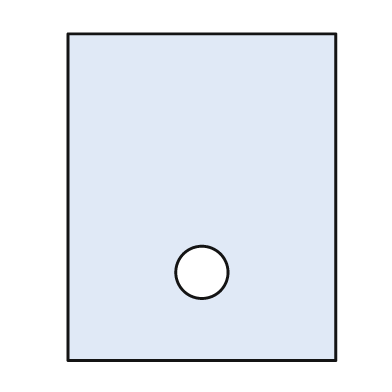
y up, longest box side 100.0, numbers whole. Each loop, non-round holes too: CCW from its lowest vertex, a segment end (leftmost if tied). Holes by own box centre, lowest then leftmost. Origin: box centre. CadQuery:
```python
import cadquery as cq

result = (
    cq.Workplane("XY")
    .moveTo(-41.0, -50.0)
    .lineTo(41.0, -50.0)
    .lineTo(41.0, 50.0)
    .lineTo(-41.0, 50.0)
    .close()
    .moveTo(0.0, -23.0)
    .circle(8.0)
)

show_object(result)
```